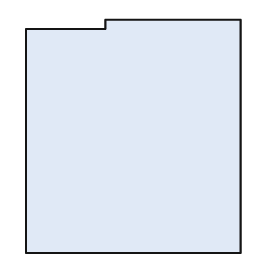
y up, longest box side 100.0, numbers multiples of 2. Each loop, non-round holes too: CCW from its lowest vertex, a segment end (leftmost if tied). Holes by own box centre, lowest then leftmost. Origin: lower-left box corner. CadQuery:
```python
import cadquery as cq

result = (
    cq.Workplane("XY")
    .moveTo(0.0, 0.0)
    .lineTo(92.0, 0.0)
    .lineTo(92.0, 100.0)
    .lineTo(34.0, 100.0)
    .lineTo(34.0, 96.0)
    .lineTo(0.0, 96.0)
    .close()
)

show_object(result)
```